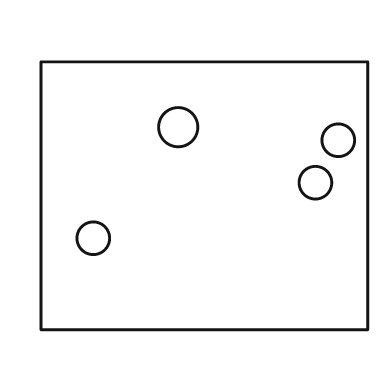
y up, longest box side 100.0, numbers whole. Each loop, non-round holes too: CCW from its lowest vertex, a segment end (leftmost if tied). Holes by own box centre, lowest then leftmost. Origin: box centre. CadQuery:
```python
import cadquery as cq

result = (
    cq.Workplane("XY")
    .moveTo(-50.0, -41.0)
    .lineTo(50.0, -41.0)
    .lineTo(50.0, 41.0)
    .lineTo(-50.0, 41.0)
    .close()
    .moveTo(-34.0, -13.0)
    .circle(5.0)
    .moveTo(34.0, 4.0)
    .circle(5.0)
    .moveTo(41.0, 17.0)
    .circle(5.0)
    .moveTo(-8.0, 21.0)
    .circle(6.0)
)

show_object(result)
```